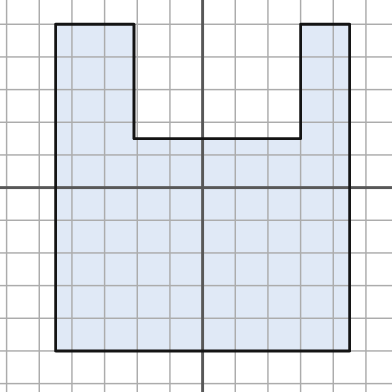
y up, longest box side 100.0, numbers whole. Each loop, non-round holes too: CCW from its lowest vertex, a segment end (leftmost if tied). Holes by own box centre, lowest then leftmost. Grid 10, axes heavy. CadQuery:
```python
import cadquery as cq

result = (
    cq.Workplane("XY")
    .moveTo(-45.0, -50.0)
    .lineTo(45.0, -50.0)
    .lineTo(45.0, 50.0)
    .lineTo(30.0, 50.0)
    .lineTo(30.0, 15.0)
    .lineTo(-21.0, 15.0)
    .lineTo(-21.0, 50.0)
    .lineTo(-45.0, 50.0)
    .close()
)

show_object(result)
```